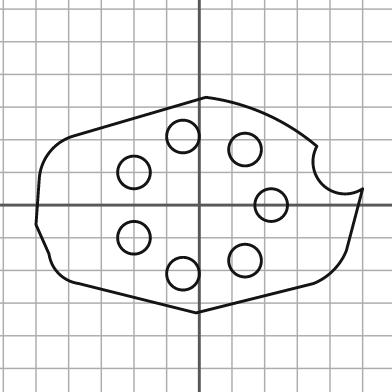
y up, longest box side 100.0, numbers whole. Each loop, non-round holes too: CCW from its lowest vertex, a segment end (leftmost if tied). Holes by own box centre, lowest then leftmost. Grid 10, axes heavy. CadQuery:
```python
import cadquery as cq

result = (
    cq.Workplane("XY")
    .moveTo(-1.0, -33.0)
    .lineTo(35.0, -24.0)
    .threePointArc((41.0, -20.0), (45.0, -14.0))
    .lineTo(50.0, 5.0)
    .threePointArc((38.0, 6.0), (36.0, 18.0))
    .threePointArc((20.0, 28.0), (2.0, 33.0))
    .lineTo(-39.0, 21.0)
    .threePointArc((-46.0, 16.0), (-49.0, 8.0))
    .lineTo(-50.0, -6.0)
    .lineTo(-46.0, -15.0)
    .threePointArc((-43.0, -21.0), (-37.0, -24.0))
    .close()
    .moveTo(-5.0, -21.0)
    .circle(5.0)
    .moveTo(14.0, -17.0)
    .circle(5.0)
    .moveTo(-20.0, -10.0)
    .circle(5.0)
    .moveTo(22.0, 0.0)
    .circle(5.0)
    .moveTo(-20.0, 10.0)
    .circle(5.0)
    .moveTo(14.0, 17.0)
    .circle(5.0)
    .moveTo(-5.0, 21.0)
    .circle(5.0)
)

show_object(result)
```